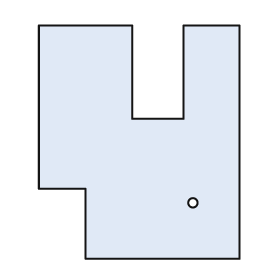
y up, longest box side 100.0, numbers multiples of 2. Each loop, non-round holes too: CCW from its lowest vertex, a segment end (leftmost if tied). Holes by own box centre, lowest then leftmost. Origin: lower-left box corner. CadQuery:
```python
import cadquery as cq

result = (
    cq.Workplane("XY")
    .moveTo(20.0, 0.0)
    .lineTo(86.0, 0.0)
    .lineTo(86.0, 100.0)
    .lineTo(62.0, 100.0)
    .lineTo(62.0, 60.0)
    .lineTo(40.0, 60.0)
    .lineTo(40.0, 100.0)
    .lineTo(0.0, 100.0)
    .lineTo(0.0, 30.0)
    .lineTo(20.0, 30.0)
    .close()
    .moveTo(66.0, 24.0)
    .circle(2.0)
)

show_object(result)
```